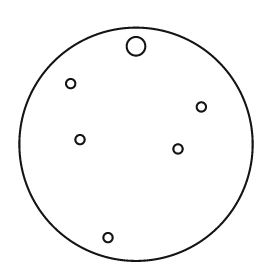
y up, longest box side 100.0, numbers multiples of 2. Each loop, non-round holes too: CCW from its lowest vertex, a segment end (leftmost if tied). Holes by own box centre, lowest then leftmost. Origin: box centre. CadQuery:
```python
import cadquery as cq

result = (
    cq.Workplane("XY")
    .moveTo(0.0, 0.0)
    .circle(50.0)
    .moveTo(-12.0, -40.0)
    .circle(2.0)
    .moveTo(18.0, -2.0)
    .circle(2.0)
    .moveTo(-24.0, 2.0)
    .circle(2.0)
    .moveTo(28.0, 16.0)
    .circle(2.0)
    .moveTo(-28.0, 26.0)
    .circle(2.0)
    .moveTo(0.0, 42.0)
    .circle(4.0)
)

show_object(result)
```